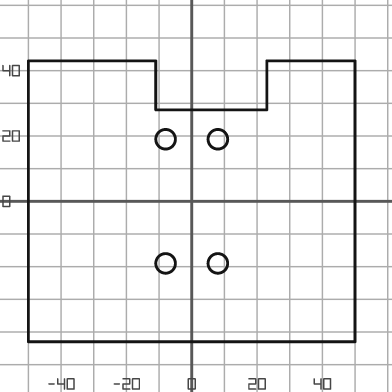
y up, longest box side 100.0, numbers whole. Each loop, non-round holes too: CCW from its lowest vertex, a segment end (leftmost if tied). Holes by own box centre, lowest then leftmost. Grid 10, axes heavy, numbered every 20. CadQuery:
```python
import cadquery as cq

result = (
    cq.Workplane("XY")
    .moveTo(-50.0, -43.0)
    .lineTo(50.0, -43.0)
    .lineTo(50.0, 43.0)
    .lineTo(23.0, 43.0)
    .lineTo(23.0, 28.0)
    .lineTo(-11.0, 28.0)
    .lineTo(-11.0, 43.0)
    .lineTo(-50.0, 43.0)
    .close()
    .moveTo(-8.0, -19.0)
    .circle(3.0)
    .moveTo(8.0, -19.0)
    .circle(3.0)
    .moveTo(-8.0, 19.0)
    .circle(3.0)
    .moveTo(8.0, 19.0)
    .circle(3.0)
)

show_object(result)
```